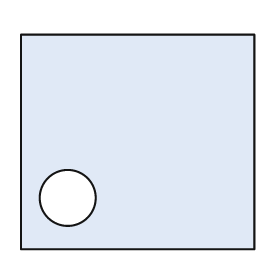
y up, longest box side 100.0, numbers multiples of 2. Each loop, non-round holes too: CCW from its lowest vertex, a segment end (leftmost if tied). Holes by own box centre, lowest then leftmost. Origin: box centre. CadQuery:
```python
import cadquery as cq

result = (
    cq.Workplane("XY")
    .moveTo(-50.0, -46.0)
    .lineTo(50.0, -46.0)
    .lineTo(50.0, 46.0)
    .lineTo(-50.0, 46.0)
    .close()
    .moveTo(-30.0, -24.0)
    .circle(12.0)
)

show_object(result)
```